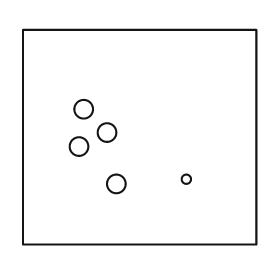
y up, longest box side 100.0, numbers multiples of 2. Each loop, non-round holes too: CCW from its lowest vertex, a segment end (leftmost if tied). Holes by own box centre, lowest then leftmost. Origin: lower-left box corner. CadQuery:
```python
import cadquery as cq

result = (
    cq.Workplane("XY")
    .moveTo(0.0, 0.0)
    .lineTo(100.0, 0.0)
    .lineTo(100.0, 92.0)
    .lineTo(0.0, 92.0)
    .close()
    .moveTo(40.0, 26.0)
    .circle(4.0)
    .moveTo(70.0, 28.0)
    .circle(2.0)
    .moveTo(24.0, 42.0)
    .circle(4.0)
    .moveTo(36.0, 48.0)
    .circle(4.0)
    .moveTo(26.0, 58.0)
    .circle(4.0)
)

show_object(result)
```